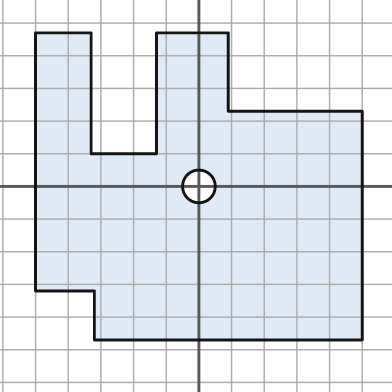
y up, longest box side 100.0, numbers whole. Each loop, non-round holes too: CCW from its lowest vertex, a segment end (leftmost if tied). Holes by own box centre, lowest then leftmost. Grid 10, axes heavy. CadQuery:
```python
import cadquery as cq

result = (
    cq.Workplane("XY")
    .moveTo(-32.0, -47.0)
    .lineTo(50.0, -47.0)
    .lineTo(50.0, 23.0)
    .lineTo(9.0, 23.0)
    .lineTo(9.0, 47.0)
    .lineTo(-13.0, 47.0)
    .lineTo(-13.0, 10.0)
    .lineTo(-33.0, 10.0)
    .lineTo(-33.0, 47.0)
    .lineTo(-50.0, 47.0)
    .lineTo(-50.0, -32.0)
    .lineTo(-32.0, -32.0)
    .close()
    .moveTo(0.0, 0.0)
    .circle(5.0)
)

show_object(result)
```